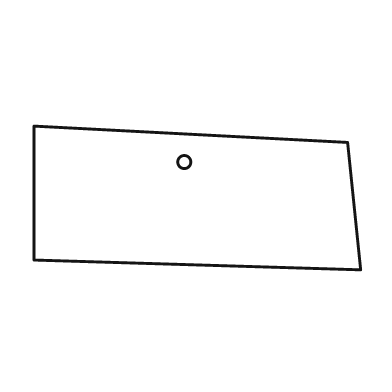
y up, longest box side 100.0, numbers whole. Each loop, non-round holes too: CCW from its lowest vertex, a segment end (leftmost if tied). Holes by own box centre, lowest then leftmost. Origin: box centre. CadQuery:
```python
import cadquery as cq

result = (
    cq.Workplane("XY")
    .moveTo(50.0, -22.0)
    .lineTo(46.0, 17.0)
    .lineTo(-50.0, 22.0)
    .lineTo(-50.0, -19.0)
    .close()
    .moveTo(-4.0, 11.0)
    .circle(2.0)
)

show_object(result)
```